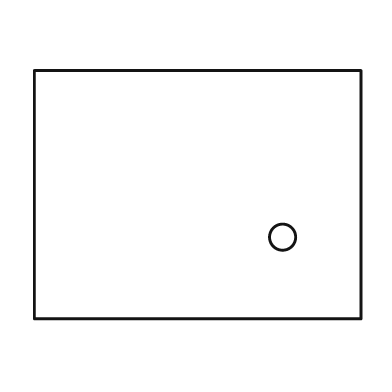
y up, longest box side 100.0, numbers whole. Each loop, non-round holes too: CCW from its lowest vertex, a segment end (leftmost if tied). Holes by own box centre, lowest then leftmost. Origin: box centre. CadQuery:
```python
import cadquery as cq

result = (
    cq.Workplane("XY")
    .moveTo(-50.0, -38.0)
    .lineTo(50.0, -38.0)
    .lineTo(50.0, 38.0)
    .lineTo(-50.0, 38.0)
    .close()
    .moveTo(26.0, -13.0)
    .circle(4.0)
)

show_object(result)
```